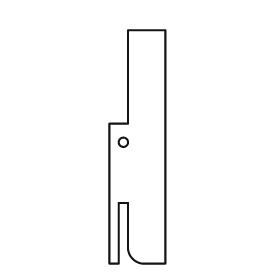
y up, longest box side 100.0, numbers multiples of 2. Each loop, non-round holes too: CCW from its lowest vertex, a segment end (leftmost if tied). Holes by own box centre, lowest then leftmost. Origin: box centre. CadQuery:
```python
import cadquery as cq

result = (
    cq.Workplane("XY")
    .moveTo(-12.0, -50.0)
    .lineTo(-8.0, -50.0)
    .lineTo(-8.0, -24.0)
    .lineTo(-4.0, -24.0)
    .lineTo(-4.0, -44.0)
    .threePointArc((-2.0, -48.0), (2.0, -50.0))
    .lineTo(12.0, -50.0)
    .lineTo(12.0, 50.0)
    .lineTo(-4.0, 50.0)
    .lineTo(-4.0, 10.0)
    .lineTo(-12.0, 10.0)
    .close()
    .moveTo(-6.0, 2.0)
    .circle(2.0)
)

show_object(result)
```